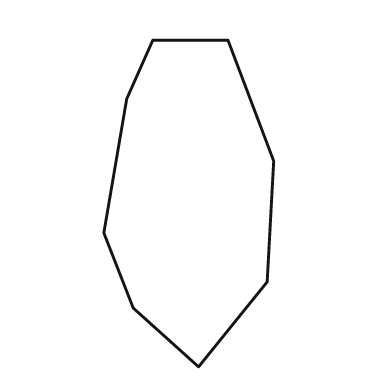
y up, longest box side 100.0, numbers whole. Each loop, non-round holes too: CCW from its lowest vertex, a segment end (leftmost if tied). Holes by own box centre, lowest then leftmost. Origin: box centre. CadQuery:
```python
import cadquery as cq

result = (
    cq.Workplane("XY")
    .moveTo(3.0, -50.0)
    .lineTo(24.0, -24.0)
    .lineTo(26.0, 13.0)
    .lineTo(12.0, 50.0)
    .lineTo(-11.0, 50.0)
    .lineTo(-19.0, 32.0)
    .lineTo(-26.0, -9.0)
    .lineTo(-17.0, -32.0)
    .close()
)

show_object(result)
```